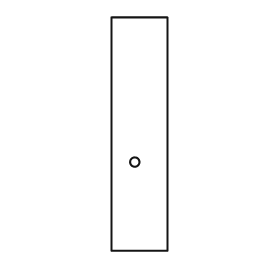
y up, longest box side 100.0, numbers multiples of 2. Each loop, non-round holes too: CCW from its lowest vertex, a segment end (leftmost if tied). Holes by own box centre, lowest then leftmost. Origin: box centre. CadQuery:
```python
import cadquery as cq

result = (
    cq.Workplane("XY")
    .moveTo(-12.0, -50.0)
    .lineTo(12.0, -50.0)
    .lineTo(12.0, 50.0)
    .lineTo(-12.0, 50.0)
    .close()
    .moveTo(-2.0, -12.0)
    .circle(2.0)
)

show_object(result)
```